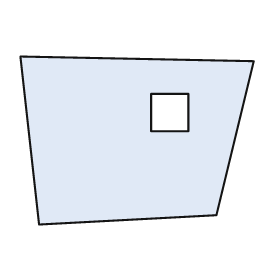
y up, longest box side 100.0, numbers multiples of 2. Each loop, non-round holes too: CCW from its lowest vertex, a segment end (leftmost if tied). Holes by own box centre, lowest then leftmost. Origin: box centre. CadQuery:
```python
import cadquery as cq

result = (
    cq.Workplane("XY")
    .moveTo(-42.0, -36.0)
    .lineTo(34.0, -32.0)
    .lineTo(50.0, 34.0)
    .lineTo(-50.0, 36.0)
    .close()
    .moveTo(6.0, 4.0)
    .lineTo(22.0, 4.0)
    .lineTo(22.0, 20.0)
    .lineTo(6.0, 20.0)
    .close()
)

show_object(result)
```